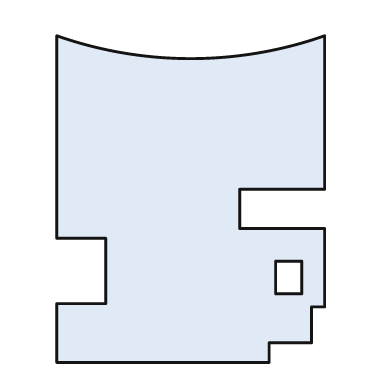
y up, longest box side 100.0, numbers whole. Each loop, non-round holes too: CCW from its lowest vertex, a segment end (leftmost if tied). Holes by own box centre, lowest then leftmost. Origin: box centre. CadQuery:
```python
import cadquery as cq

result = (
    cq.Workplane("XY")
    .moveTo(-41.0, -50.0)
    .lineTo(24.0, -50.0)
    .lineTo(24.0, -44.0)
    .lineTo(37.0, -44.0)
    .lineTo(37.0, -33.0)
    .lineTo(41.0, -33.0)
    .lineTo(41.0, -9.0)
    .lineTo(15.0, -9.0)
    .lineTo(15.0, 3.0)
    .lineTo(41.0, 3.0)
    .lineTo(41.0, 50.0)
    .threePointArc((0.0, 43.0), (-41.0, 50.0))
    .lineTo(-41.0, -12.0)
    .lineTo(-26.0, -12.0)
    .lineTo(-26.0, -32.0)
    .lineTo(-41.0, -32.0)
    .close()
    .moveTo(26.0, -29.0)
    .lineTo(34.0, -29.0)
    .lineTo(34.0, -19.0)
    .lineTo(26.0, -19.0)
    .close()
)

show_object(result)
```